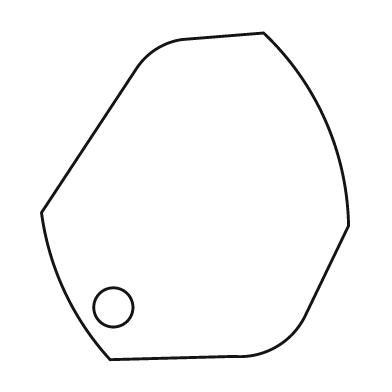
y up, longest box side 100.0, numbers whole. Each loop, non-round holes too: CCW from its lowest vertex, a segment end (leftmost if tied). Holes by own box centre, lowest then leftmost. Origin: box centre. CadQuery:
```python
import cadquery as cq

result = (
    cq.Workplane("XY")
    .moveTo(-26.0, -50.0)
    .lineTo(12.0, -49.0)
    .threePointArc((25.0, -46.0), (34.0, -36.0))
    .lineTo(47.0, -9.0)
    .threePointArc((40.0, 23.0), (21.0, 50.0))
    .lineTo(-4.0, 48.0)
    .threePointArc((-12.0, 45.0), (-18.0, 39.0))
    .lineTo(-47.0, -5.0)
    .threePointArc((-40.0, -29.0), (-26.0, -50.0))
    .close()
    .moveTo(-25.0, -34.0)
    .circle(6.0)
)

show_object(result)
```